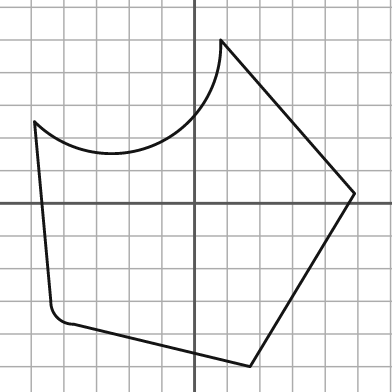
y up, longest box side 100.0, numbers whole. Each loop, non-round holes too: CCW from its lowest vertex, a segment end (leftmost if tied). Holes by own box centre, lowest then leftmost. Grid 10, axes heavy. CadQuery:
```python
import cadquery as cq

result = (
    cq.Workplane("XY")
    .moveTo(17.0, -50.0)
    .lineTo(49.0, 3.0)
    .lineTo(8.0, 50.0)
    .threePointArc((-12.0, 18.0), (-49.0, 25.0))
    .lineTo(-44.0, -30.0)
    .threePointArc((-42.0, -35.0), (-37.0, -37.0))
    .close()
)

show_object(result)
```